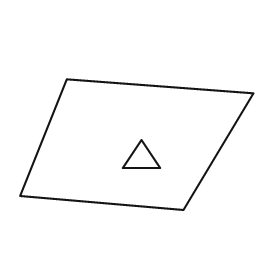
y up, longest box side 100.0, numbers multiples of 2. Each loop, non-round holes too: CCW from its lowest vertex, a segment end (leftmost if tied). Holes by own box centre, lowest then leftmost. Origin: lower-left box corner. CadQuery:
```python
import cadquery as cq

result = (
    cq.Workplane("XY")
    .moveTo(70.0, 0.0)
    .lineTo(100.0, 50.0)
    .lineTo(20.0, 56.0)
    .lineTo(0.0, 6.0)
    .close()
    .moveTo(44.0, 18.0)
    .lineTo(60.0, 18.0)
    .lineTo(52.0, 30.0)
    .close()
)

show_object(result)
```